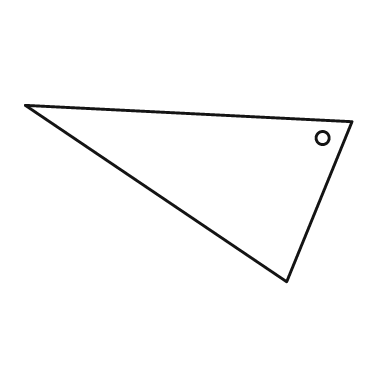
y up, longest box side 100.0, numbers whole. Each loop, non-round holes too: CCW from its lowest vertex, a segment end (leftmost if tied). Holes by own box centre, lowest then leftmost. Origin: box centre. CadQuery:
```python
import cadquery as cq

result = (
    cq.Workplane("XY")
    .moveTo(30.0, -27.0)
    .lineTo(50.0, 22.0)
    .lineTo(-50.0, 27.0)
    .close()
    .moveTo(41.0, 17.0)
    .circle(2.0)
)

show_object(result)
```